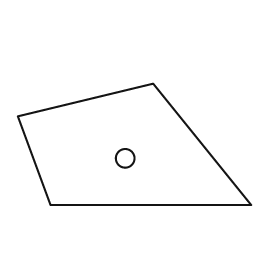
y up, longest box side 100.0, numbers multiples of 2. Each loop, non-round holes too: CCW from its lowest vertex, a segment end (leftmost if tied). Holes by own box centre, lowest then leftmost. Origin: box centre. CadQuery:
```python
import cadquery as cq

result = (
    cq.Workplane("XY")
    .moveTo(-36.0, -26.0)
    .lineTo(50.0, -26.0)
    .lineTo(8.0, 26.0)
    .lineTo(-50.0, 12.0)
    .close()
    .moveTo(-4.0, -6.0)
    .circle(4.0)
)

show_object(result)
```